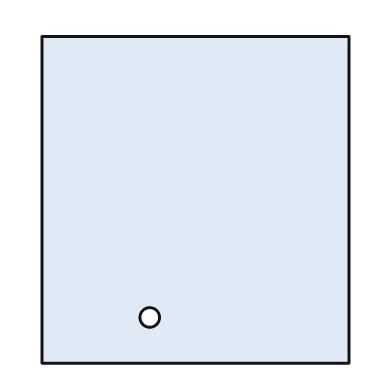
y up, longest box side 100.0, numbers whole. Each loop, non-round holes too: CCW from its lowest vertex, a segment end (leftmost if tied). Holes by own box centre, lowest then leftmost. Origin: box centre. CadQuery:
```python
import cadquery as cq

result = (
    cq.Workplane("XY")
    .moveTo(-47.0, -50.0)
    .lineTo(47.0, -50.0)
    .lineTo(47.0, 50.0)
    .lineTo(-47.0, 50.0)
    .close()
    .moveTo(-14.0, -36.0)
    .circle(3.0)
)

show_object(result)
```